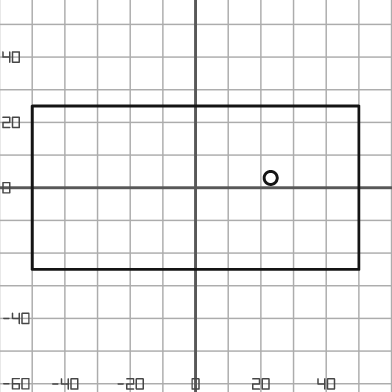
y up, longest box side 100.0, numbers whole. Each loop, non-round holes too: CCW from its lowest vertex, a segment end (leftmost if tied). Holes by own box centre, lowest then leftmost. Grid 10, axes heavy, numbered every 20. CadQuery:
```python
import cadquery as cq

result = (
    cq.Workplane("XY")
    .moveTo(-50.0, -25.0)
    .lineTo(50.0, -25.0)
    .lineTo(50.0, 25.0)
    .lineTo(-50.0, 25.0)
    .close()
    .moveTo(23.0, 3.0)
    .circle(2.0)
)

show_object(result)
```